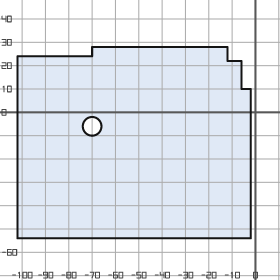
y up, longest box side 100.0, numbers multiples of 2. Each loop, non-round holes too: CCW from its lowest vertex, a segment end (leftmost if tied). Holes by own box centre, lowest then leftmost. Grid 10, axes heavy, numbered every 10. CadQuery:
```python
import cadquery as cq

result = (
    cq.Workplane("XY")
    .moveTo(-102.0, -54.0)
    .lineTo(-2.0, -54.0)
    .lineTo(-2.0, 10.0)
    .lineTo(-6.0, 10.0)
    .lineTo(-6.0, 22.0)
    .lineTo(-12.0, 22.0)
    .lineTo(-12.0, 28.0)
    .lineTo(-70.0, 28.0)
    .lineTo(-70.0, 24.0)
    .lineTo(-102.0, 24.0)
    .close()
    .moveTo(-70.0, -6.0)
    .circle(4.0)
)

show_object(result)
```